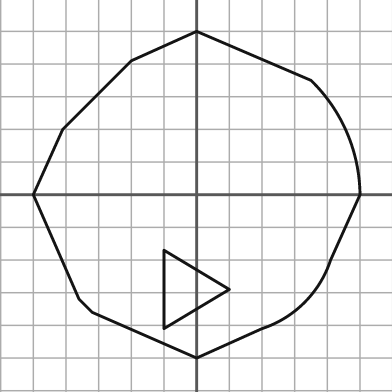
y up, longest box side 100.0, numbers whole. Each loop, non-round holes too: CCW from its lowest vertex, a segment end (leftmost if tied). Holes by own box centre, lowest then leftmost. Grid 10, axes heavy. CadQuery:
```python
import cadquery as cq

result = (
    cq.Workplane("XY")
    .moveTo(0.0, -50.0)
    .lineTo(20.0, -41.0)
    .threePointArc((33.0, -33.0), (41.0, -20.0))
    .lineTo(50.0, 0.0)
    .threePointArc((46.0, 19.0), (35.0, 35.0))
    .lineTo(0.0, 50.0)
    .lineTo(-20.0, 41.0)
    .lineTo(-41.0, 20.0)
    .lineTo(-50.0, 0.0)
    .lineTo(-36.0, -32.0)
    .lineTo(-32.0, -36.0)
    .close()
    .moveTo(-10.0, -41.0)
    .lineTo(10.0, -29.0)
    .lineTo(-10.0, -17.0)
    .close()
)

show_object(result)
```